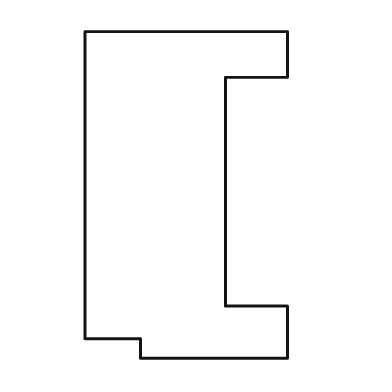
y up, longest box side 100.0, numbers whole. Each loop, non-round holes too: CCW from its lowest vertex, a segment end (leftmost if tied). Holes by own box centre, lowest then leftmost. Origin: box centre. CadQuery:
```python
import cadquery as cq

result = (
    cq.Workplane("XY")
    .moveTo(-14.0, -50.0)
    .lineTo(31.0, -50.0)
    .lineTo(31.0, -34.0)
    .lineTo(12.0, -34.0)
    .lineTo(12.0, 36.0)
    .lineTo(31.0, 36.0)
    .lineTo(31.0, 50.0)
    .lineTo(-31.0, 50.0)
    .lineTo(-31.0, -44.0)
    .lineTo(-14.0, -44.0)
    .close()
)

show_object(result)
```